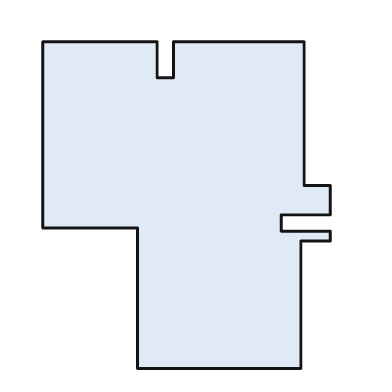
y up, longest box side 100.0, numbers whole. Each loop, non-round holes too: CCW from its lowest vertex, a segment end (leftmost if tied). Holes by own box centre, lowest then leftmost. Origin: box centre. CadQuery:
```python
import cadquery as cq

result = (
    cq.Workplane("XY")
    .moveTo(-15.0, -50.0)
    .lineTo(35.0, -50.0)
    .lineTo(35.0, -11.0)
    .lineTo(44.0, -11.0)
    .lineTo(44.0, -8.0)
    .lineTo(29.0, -8.0)
    .lineTo(29.0, -3.0)
    .lineTo(44.0, -3.0)
    .lineTo(44.0, 6.0)
    .lineTo(36.0, 6.0)
    .lineTo(36.0, 50.0)
    .lineTo(-4.0, 50.0)
    .lineTo(-4.0, 39.0)
    .lineTo(-9.0, 39.0)
    .lineTo(-9.0, 50.0)
    .lineTo(-44.0, 50.0)
    .lineTo(-44.0, -7.0)
    .lineTo(-15.0, -7.0)
    .close()
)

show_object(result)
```